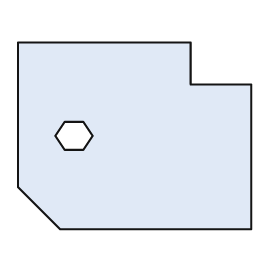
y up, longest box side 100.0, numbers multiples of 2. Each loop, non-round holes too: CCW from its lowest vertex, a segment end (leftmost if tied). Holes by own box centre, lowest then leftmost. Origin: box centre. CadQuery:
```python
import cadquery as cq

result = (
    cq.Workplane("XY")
    .moveTo(-32.0, -40.0)
    .lineTo(50.0, -40.0)
    .lineTo(50.0, 22.0)
    .lineTo(24.0, 22.0)
    .lineTo(24.0, 40.0)
    .lineTo(-50.0, 40.0)
    .lineTo(-50.0, -22.0)
    .close()
    .moveTo(-30.0, -6.0)
    .lineTo(-22.0, -6.0)
    .lineTo(-18.0, 0.0)
    .lineTo(-22.0, 6.0)
    .lineTo(-30.0, 6.0)
    .lineTo(-34.0, 0.0)
    .close()
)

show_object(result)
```